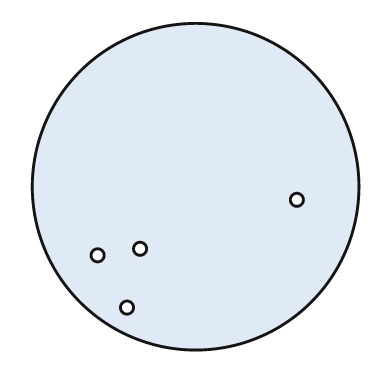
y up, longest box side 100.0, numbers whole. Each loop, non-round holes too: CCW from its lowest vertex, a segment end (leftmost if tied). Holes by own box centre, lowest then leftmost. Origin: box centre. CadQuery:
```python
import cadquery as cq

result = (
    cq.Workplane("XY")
    .moveTo(0.0, 0.0)
    .circle(50.0)
    .moveTo(-21.0, -37.0)
    .circle(2.0)
    .moveTo(-30.0, -21.0)
    .circle(2.0)
    .moveTo(-17.0, -19.0)
    .circle(2.0)
    .moveTo(31.0, -4.0)
    .circle(2.0)
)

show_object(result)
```